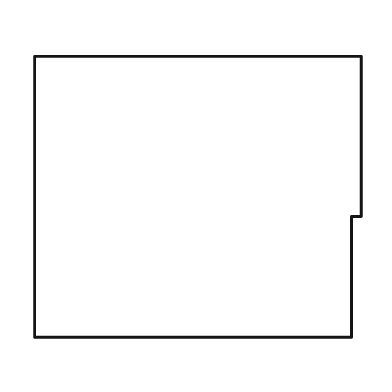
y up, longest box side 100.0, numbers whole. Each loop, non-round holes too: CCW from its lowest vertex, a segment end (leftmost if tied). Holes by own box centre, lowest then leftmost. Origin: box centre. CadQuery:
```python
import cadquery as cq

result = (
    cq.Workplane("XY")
    .moveTo(-50.0, -43.0)
    .lineTo(47.0, -43.0)
    .lineTo(47.0, -6.0)
    .lineTo(50.0, -6.0)
    .lineTo(50.0, 43.0)
    .lineTo(-50.0, 43.0)
    .close()
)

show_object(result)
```